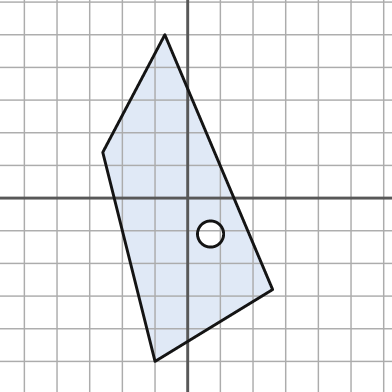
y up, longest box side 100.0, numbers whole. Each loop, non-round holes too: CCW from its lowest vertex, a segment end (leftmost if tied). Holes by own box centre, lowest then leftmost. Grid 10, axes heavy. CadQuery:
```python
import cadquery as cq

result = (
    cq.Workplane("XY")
    .moveTo(-10.0, -50.0)
    .lineTo(26.0, -28.0)
    .lineTo(-7.0, 50.0)
    .lineTo(-26.0, 14.0)
    .close()
    .moveTo(7.0, -11.0)
    .circle(4.0)
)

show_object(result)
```